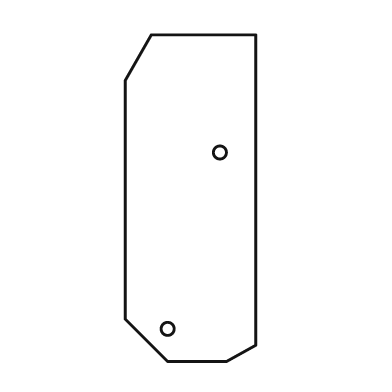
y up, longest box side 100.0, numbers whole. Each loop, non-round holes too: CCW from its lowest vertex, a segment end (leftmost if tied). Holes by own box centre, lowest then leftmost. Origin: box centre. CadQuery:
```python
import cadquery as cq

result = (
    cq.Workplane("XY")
    .moveTo(-7.0, -50.0)
    .lineTo(11.0, -50.0)
    .lineTo(20.0, -45.0)
    .lineTo(20.0, 50.0)
    .lineTo(-12.0, 50.0)
    .lineTo(-20.0, 36.0)
    .lineTo(-20.0, -37.0)
    .close()
    .moveTo(-7.0, -40.0)
    .circle(2.0)
    .moveTo(9.0, 14.0)
    .circle(2.0)
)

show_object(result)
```